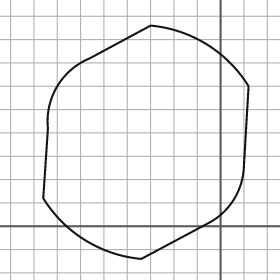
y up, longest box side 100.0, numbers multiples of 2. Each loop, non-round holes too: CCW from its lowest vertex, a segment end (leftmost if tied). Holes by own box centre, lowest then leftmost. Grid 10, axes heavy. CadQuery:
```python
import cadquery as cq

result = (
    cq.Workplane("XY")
    .moveTo(-34.0, -14.0)
    .lineTo(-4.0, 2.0)
    .threePointArc((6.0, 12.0), (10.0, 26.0))
    .lineTo(12.0, 60.0)
    .threePointArc((-6.0, 78.0), (-30.0, 86.0))
    .lineTo(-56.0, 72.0)
    .threePointArc((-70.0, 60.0), (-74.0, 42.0))
    .lineTo(-76.0, 12.0)
    .threePointArc((-58.0, -6.0), (-34.0, -14.0))
    .close()
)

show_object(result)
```